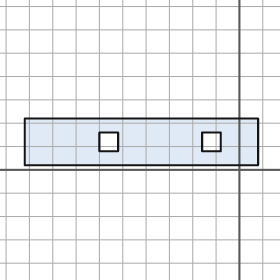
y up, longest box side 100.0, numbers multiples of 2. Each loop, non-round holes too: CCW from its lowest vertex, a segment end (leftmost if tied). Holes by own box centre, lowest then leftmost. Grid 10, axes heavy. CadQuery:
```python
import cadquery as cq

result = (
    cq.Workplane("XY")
    .moveTo(-92.0, 2.0)
    .lineTo(8.0, 2.0)
    .lineTo(8.0, 22.0)
    .lineTo(-92.0, 22.0)
    .close()
    .moveTo(-60.0, 8.0)
    .lineTo(-52.0, 8.0)
    .lineTo(-52.0, 16.0)
    .lineTo(-60.0, 16.0)
    .close()
    .moveTo(-16.0, 8.0)
    .lineTo(-8.0, 8.0)
    .lineTo(-8.0, 16.0)
    .lineTo(-16.0, 16.0)
    .close()
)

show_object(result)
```